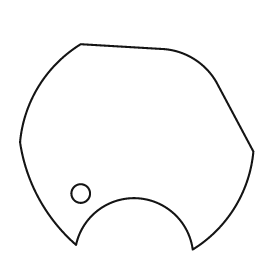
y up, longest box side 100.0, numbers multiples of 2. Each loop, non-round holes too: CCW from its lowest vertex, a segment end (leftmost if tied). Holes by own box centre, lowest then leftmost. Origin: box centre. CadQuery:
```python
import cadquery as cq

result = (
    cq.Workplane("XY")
    .moveTo(24.0, -44.0)
    .threePointArc((42.0, -26.0), (50.0, -2.0))
    .lineTo(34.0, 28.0)
    .threePointArc((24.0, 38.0), (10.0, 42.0))
    .lineTo(-24.0, 44.0)
    .threePointArc((-42.0, 26.0), (-50.0, 2.0))
    .threePointArc((-42.0, -22.0), (-26.0, -42.0))
    .threePointArc((0.0, -22.0), (24.0, -44.0))
    .close()
    .moveTo(-24.0, -20.0)
    .circle(4.0)
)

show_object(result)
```